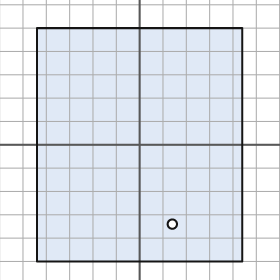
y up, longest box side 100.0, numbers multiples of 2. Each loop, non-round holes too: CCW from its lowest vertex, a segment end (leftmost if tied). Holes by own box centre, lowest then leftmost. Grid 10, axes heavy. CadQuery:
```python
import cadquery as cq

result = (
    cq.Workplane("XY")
    .moveTo(-44.0, -50.0)
    .lineTo(44.0, -50.0)
    .lineTo(44.0, 50.0)
    .lineTo(-44.0, 50.0)
    .close()
    .moveTo(14.0, -34.0)
    .circle(2.0)
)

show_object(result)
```